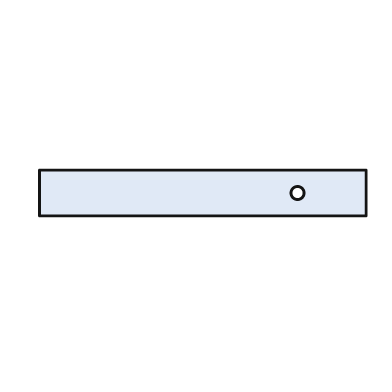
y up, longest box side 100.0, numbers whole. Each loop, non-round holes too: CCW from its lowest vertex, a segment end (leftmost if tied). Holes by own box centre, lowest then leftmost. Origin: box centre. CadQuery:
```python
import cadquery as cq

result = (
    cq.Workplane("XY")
    .moveTo(-50.0, -7.0)
    .lineTo(50.0, -7.0)
    .lineTo(50.0, 7.0)
    .lineTo(-50.0, 7.0)
    .close()
    .moveTo(29.0, 0.0)
    .circle(2.0)
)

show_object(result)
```